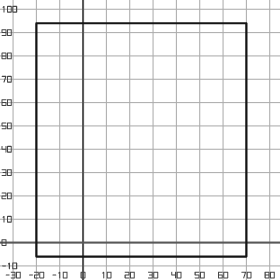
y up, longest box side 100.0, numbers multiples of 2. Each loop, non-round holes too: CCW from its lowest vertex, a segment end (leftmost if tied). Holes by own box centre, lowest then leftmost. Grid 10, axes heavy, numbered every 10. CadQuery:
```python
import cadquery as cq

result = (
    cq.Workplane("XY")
    .moveTo(-20.0, -6.0)
    .lineTo(70.0, -6.0)
    .lineTo(70.0, 94.0)
    .lineTo(-20.0, 94.0)
    .close()
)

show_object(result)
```